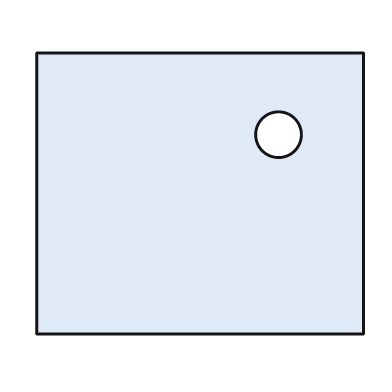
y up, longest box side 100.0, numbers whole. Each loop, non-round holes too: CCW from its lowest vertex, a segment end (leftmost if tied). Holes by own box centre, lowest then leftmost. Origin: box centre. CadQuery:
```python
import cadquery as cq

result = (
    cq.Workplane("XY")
    .moveTo(-50.0, -43.0)
    .lineTo(50.0, -43.0)
    .lineTo(50.0, 43.0)
    .lineTo(-50.0, 43.0)
    .close()
    .moveTo(24.0, 18.0)
    .circle(7.0)
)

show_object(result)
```